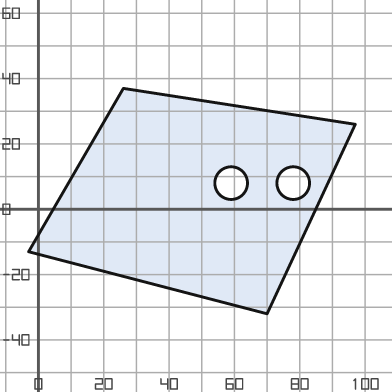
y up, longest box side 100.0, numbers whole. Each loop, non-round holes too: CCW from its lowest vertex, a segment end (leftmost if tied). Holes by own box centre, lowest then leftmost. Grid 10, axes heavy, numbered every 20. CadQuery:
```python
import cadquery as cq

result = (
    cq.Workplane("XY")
    .moveTo(70.0, -32.0)
    .lineTo(97.0, 26.0)
    .lineTo(26.0, 37.0)
    .lineTo(-3.0, -13.0)
    .close()
    .moveTo(59.0, 8.0)
    .circle(5.0)
    .moveTo(78.0, 8.0)
    .circle(5.0)
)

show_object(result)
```